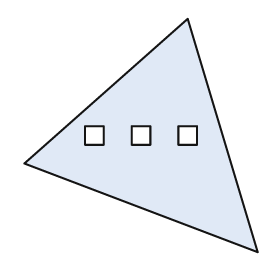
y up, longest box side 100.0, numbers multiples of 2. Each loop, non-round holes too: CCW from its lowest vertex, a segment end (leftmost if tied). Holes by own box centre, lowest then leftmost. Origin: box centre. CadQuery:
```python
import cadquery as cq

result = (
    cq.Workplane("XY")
    .moveTo(50.0, -50.0)
    .lineTo(20.0, 50.0)
    .lineTo(-50.0, -12.0)
    .close()
    .moveTo(-24.0, -4.0)
    .lineTo(-16.0, -4.0)
    .lineTo(-16.0, 4.0)
    .lineTo(-24.0, 4.0)
    .close()
    .moveTo(-4.0, -4.0)
    .lineTo(4.0, -4.0)
    .lineTo(4.0, 4.0)
    .lineTo(-4.0, 4.0)
    .close()
    .moveTo(16.0, -4.0)
    .lineTo(24.0, -4.0)
    .lineTo(24.0, 4.0)
    .lineTo(16.0, 4.0)
    .close()
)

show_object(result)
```